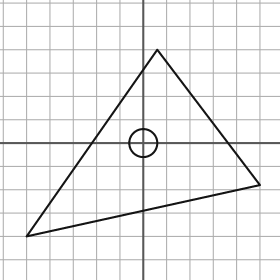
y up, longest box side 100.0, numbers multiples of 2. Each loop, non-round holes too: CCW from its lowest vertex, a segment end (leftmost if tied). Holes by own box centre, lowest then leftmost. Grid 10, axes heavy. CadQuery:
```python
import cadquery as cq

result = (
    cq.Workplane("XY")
    .moveTo(-50.0, -40.0)
    .lineTo(50.0, -18.0)
    .lineTo(6.0, 40.0)
    .close()
    .moveTo(0.0, 0.0)
    .circle(6.0)
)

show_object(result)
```